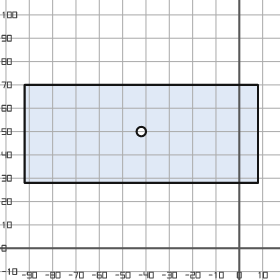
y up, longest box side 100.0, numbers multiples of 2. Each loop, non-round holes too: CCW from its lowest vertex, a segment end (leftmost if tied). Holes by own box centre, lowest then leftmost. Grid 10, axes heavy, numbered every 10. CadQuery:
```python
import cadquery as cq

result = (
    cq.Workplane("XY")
    .moveTo(-92.0, 28.0)
    .lineTo(8.0, 28.0)
    .lineTo(8.0, 70.0)
    .lineTo(-92.0, 70.0)
    .close()
    .moveTo(-42.0, 50.0)
    .circle(2.0)
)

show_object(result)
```